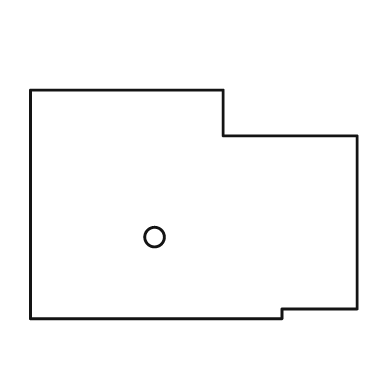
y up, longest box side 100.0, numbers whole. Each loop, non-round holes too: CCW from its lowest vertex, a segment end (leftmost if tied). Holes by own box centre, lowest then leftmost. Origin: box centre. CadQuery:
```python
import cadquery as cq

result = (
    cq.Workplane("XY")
    .moveTo(-50.0, -35.0)
    .lineTo(27.0, -35.0)
    .lineTo(27.0, -32.0)
    .lineTo(50.0, -32.0)
    .lineTo(50.0, 21.0)
    .lineTo(9.0, 21.0)
    .lineTo(9.0, 35.0)
    .lineTo(-50.0, 35.0)
    .close()
    .moveTo(-12.0, -10.0)
    .circle(3.0)
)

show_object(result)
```